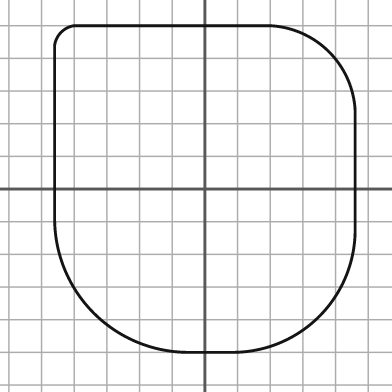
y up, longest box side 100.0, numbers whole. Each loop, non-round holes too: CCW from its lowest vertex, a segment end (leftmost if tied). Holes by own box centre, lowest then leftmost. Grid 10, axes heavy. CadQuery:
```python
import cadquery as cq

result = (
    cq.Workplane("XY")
    .moveTo(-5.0, -50.0)
    .lineTo(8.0, -50.0)
    .threePointArc((35.0, -39.0), (46.0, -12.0))
    .lineTo(46.0, 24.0)
    .threePointArc((38.0, 42.0), (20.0, 50.0))
    .lineTo(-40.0, 50.0)
    .threePointArc((-44.0, 48.0), (-46.0, 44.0))
    .lineTo(-46.0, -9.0)
    .threePointArc((-34.0, -38.0), (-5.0, -50.0))
    .close()
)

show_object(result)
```